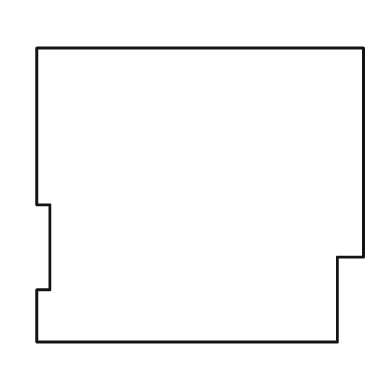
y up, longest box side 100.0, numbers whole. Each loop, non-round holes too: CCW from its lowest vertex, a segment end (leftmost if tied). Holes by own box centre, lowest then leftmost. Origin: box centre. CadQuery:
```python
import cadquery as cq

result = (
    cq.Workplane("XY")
    .moveTo(-50.0, -45.0)
    .lineTo(42.0, -45.0)
    .lineTo(42.0, -19.0)
    .lineTo(50.0, -19.0)
    .lineTo(50.0, 45.0)
    .lineTo(-50.0, 45.0)
    .lineTo(-50.0, -3.0)
    .lineTo(-46.0, -3.0)
    .lineTo(-46.0, -29.0)
    .lineTo(-50.0, -29.0)
    .close()
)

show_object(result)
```